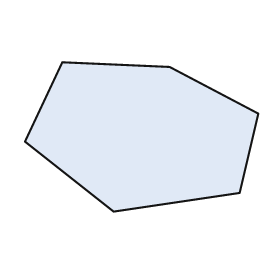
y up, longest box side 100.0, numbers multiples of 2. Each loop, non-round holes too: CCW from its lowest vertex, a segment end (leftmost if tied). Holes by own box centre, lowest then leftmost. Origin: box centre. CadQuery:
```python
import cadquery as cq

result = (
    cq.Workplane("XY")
    .moveTo(-12.0, -32.0)
    .lineTo(42.0, -24.0)
    .lineTo(50.0, 10.0)
    .lineTo(12.0, 30.0)
    .lineTo(-34.0, 32.0)
    .lineTo(-50.0, -2.0)
    .close()
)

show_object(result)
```